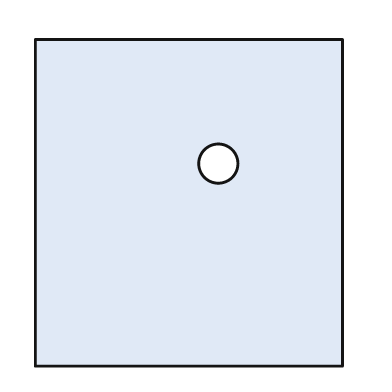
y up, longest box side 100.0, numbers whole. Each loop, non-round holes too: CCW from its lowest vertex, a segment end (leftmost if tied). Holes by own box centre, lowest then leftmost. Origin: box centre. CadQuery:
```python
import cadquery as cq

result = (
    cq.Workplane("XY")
    .moveTo(-47.0, -50.0)
    .lineTo(47.0, -50.0)
    .lineTo(47.0, 50.0)
    .lineTo(-47.0, 50.0)
    .close()
    .moveTo(9.0, 12.0)
    .circle(6.0)
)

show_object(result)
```